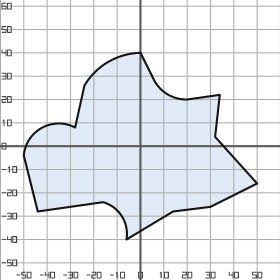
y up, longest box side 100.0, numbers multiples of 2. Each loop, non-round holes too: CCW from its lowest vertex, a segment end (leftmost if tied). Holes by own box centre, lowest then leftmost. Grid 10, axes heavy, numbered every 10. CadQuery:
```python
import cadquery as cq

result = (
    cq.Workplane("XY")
    .moveTo(-6.0, -40.0)
    .lineTo(14.0, -28.0)
    .lineTo(30.0, -26.0)
    .lineTo(50.0, -16.0)
    .lineTo(32.0, 4.0)
    .lineTo(34.0, 22.0)
    .lineTo(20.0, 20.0)
    .threePointArc((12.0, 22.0), (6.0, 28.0))
    .lineTo(0.0, 40.0)
    .threePointArc((-14.0, 36.0), (-24.0, 26.0))
    .lineTo(-28.0, 8.0)
    .threePointArc((-42.0, 8.0), (-50.0, -4.0))
    .lineTo(-44.0, -28.0)
    .lineTo(-16.0, -24.0)
    .threePointArc((-8.0, -30.0), (-6.0, -40.0))
    .close()
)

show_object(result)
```